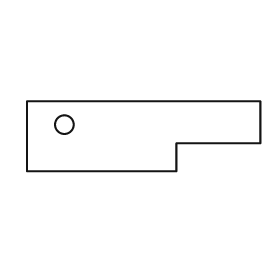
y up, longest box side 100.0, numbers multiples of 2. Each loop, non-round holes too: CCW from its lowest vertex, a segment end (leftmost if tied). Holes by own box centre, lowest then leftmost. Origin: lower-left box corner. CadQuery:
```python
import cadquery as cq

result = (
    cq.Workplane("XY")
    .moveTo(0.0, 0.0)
    .lineTo(64.0, 0.0)
    .lineTo(64.0, 12.0)
    .lineTo(100.0, 12.0)
    .lineTo(100.0, 30.0)
    .lineTo(0.0, 30.0)
    .close()
    .moveTo(16.0, 20.0)
    .circle(4.0)
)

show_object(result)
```